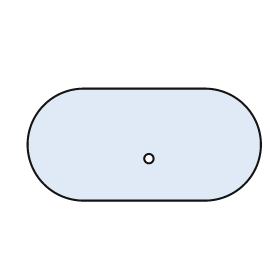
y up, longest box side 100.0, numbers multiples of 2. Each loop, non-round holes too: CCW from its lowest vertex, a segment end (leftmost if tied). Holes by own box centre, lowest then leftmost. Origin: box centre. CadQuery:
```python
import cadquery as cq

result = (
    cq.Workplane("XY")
    .moveTo(-26.0, -24.0)
    .lineTo(26.0, -24.0)
    .threePointArc((50.0, 0.0), (26.0, 24.0))
    .lineTo(-26.0, 24.0)
    .threePointArc((-50.0, 0.0), (-26.0, -24.0))
    .close()
    .moveTo(2.0, -6.0)
    .circle(2.0)
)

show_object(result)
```